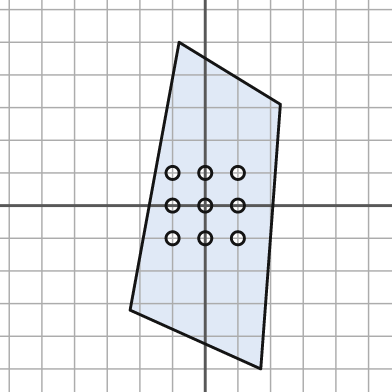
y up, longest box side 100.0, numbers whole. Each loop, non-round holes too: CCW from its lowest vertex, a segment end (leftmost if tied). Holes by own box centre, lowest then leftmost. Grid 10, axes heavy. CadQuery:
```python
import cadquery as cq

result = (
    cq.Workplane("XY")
    .moveTo(17.0, -50.0)
    .lineTo(23.0, 31.0)
    .lineTo(-8.0, 50.0)
    .lineTo(-23.0, -32.0)
    .close()
    .moveTo(-10.0, -10.0)
    .circle(2.0)
    .moveTo(0.0, -10.0)
    .circle(2.0)
    .moveTo(10.0, -10.0)
    .circle(2.0)
    .moveTo(-10.0, 0.0)
    .circle(2.0)
    .moveTo(0.0, 0.0)
    .circle(2.0)
    .moveTo(10.0, 0.0)
    .circle(2.0)
    .moveTo(-10.0, 10.0)
    .circle(2.0)
    .moveTo(0.0, 10.0)
    .circle(2.0)
    .moveTo(10.0, 10.0)
    .circle(2.0)
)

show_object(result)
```